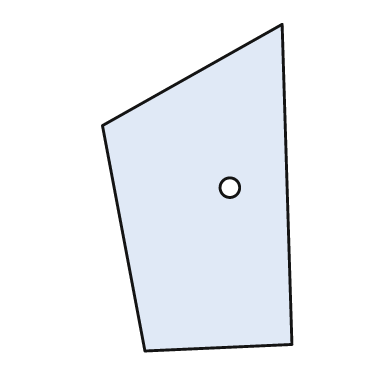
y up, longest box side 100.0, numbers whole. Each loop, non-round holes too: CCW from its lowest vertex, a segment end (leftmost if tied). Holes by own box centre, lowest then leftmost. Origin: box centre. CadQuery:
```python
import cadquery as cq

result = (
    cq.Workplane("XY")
    .moveTo(-16.0, -50.0)
    .lineTo(29.0, -48.0)
    .lineTo(26.0, 50.0)
    .lineTo(-29.0, 19.0)
    .close()
    .moveTo(10.0, 0.0)
    .circle(3.0)
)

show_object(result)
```